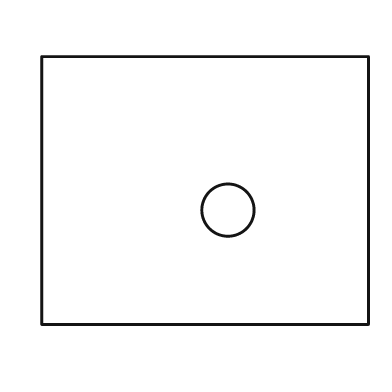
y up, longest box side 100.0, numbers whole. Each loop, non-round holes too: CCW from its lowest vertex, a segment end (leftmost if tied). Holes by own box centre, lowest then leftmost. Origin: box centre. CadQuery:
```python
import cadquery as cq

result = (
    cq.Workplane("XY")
    .moveTo(-50.0, -41.0)
    .lineTo(50.0, -41.0)
    .lineTo(50.0, 41.0)
    .lineTo(-50.0, 41.0)
    .close()
    .moveTo(7.0, -6.0)
    .circle(8.0)
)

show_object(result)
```